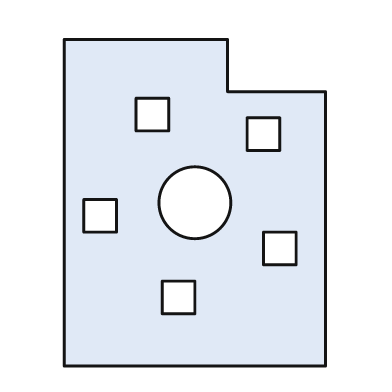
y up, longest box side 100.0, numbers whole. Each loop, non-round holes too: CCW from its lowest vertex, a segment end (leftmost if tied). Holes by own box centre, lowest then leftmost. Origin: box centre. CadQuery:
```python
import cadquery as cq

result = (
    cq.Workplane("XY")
    .moveTo(-40.0, -50.0)
    .lineTo(40.0, -50.0)
    .lineTo(40.0, 34.0)
    .lineTo(10.0, 34.0)
    .lineTo(10.0, 50.0)
    .lineTo(-40.0, 50.0)
    .close()
    .moveTo(-10.0, -34.0)
    .lineTo(0.0, -34.0)
    .lineTo(0.0, -24.0)
    .lineTo(-10.0, -24.0)
    .close()
    .moveTo(21.0, -19.0)
    .lineTo(31.0, -19.0)
    .lineTo(31.0, -9.0)
    .lineTo(21.0, -9.0)
    .close()
    .moveTo(-34.0, -9.0)
    .lineTo(-24.0, -9.0)
    .lineTo(-24.0, 1.0)
    .lineTo(-34.0, 1.0)
    .close()
    .moveTo(0.0, 0.0)
    .circle(11.0)
    .moveTo(16.0, 16.0)
    .lineTo(26.0, 16.0)
    .lineTo(26.0, 26.0)
    .lineTo(16.0, 26.0)
    .close()
    .moveTo(-18.0, 22.0)
    .lineTo(-8.0, 22.0)
    .lineTo(-8.0, 32.0)
    .lineTo(-18.0, 32.0)
    .close()
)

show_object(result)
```